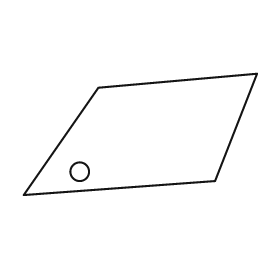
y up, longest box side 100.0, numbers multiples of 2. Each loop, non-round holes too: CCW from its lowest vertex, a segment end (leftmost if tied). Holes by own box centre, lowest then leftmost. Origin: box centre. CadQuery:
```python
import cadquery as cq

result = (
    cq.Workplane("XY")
    .moveTo(-50.0, -26.0)
    .lineTo(32.0, -20.0)
    .lineTo(50.0, 26.0)
    .lineTo(-18.0, 20.0)
    .close()
    .moveTo(-26.0, -16.0)
    .circle(4.0)
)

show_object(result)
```